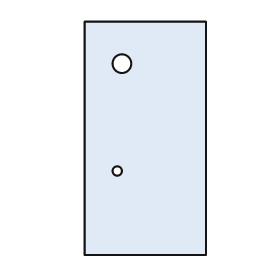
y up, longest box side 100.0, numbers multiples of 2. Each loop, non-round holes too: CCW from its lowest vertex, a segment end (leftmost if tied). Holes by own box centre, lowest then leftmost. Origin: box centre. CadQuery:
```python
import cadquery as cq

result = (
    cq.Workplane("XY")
    .moveTo(-26.0, -50.0)
    .lineTo(26.0, -50.0)
    .lineTo(26.0, 50.0)
    .lineTo(-26.0, 50.0)
    .close()
    .moveTo(-12.0, -14.0)
    .circle(2.0)
    .moveTo(-10.0, 32.0)
    .circle(4.0)
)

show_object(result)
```